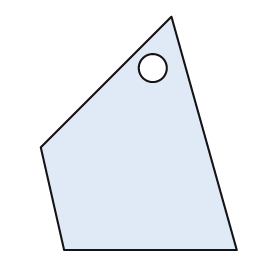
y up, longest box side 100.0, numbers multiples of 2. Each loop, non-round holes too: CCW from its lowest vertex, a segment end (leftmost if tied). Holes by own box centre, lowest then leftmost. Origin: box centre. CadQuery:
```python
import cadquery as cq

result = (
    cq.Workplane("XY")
    .moveTo(-32.0, -50.0)
    .lineTo(42.0, -50.0)
    .lineTo(14.0, 50.0)
    .lineTo(-42.0, -6.0)
    .close()
    .moveTo(6.0, 28.0)
    .circle(6.0)
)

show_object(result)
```